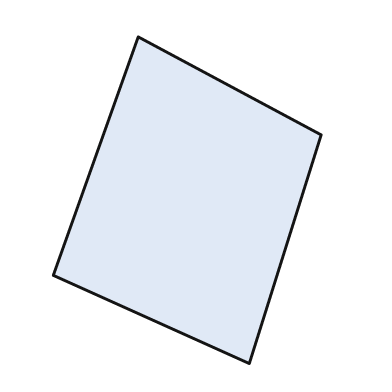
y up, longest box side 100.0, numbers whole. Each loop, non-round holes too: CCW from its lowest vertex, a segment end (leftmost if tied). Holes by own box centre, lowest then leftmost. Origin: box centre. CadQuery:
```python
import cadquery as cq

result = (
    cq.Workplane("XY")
    .moveTo(19.0, -50.0)
    .lineTo(41.0, 20.0)
    .lineTo(-15.0, 50.0)
    .lineTo(-41.0, -23.0)
    .close()
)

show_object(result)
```